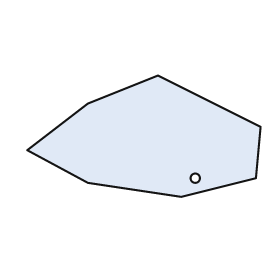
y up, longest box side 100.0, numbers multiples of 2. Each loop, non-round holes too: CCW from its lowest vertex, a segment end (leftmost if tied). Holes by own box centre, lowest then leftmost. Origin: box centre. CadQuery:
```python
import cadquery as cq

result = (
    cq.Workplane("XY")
    .moveTo(16.0, -26.0)
    .lineTo(48.0, -18.0)
    .lineTo(50.0, 4.0)
    .lineTo(6.0, 26.0)
    .lineTo(-24.0, 14.0)
    .lineTo(-50.0, -6.0)
    .lineTo(-24.0, -20.0)
    .close()
    .moveTo(22.0, -18.0)
    .circle(2.0)
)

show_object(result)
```